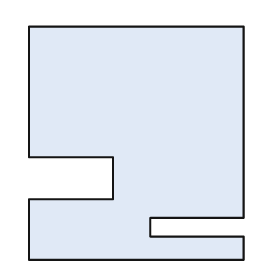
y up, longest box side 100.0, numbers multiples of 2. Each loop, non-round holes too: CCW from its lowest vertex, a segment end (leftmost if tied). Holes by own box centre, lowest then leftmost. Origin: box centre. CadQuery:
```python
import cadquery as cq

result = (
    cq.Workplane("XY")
    .moveTo(-46.0, -50.0)
    .lineTo(46.0, -50.0)
    .lineTo(46.0, -40.0)
    .lineTo(6.0, -40.0)
    .lineTo(6.0, -32.0)
    .lineTo(46.0, -32.0)
    .lineTo(46.0, 50.0)
    .lineTo(-46.0, 50.0)
    .lineTo(-46.0, -6.0)
    .lineTo(-10.0, -6.0)
    .lineTo(-10.0, -24.0)
    .lineTo(-46.0, -24.0)
    .close()
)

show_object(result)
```